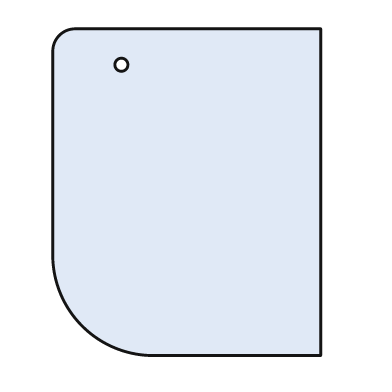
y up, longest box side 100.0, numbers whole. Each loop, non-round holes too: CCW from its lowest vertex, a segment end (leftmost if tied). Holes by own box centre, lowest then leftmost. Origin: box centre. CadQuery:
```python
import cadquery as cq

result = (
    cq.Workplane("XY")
    .moveTo(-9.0, -50.0)
    .lineTo(41.0, -50.0)
    .lineTo(41.0, 50.0)
    .lineTo(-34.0, 50.0)
    .threePointArc((-39.0, 48.0), (-41.0, 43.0))
    .lineTo(-41.0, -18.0)
    .threePointArc((-32.0, -41.0), (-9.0, -50.0))
    .close()
    .moveTo(-20.0, 39.0)
    .circle(2.0)
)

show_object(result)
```